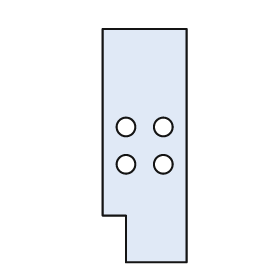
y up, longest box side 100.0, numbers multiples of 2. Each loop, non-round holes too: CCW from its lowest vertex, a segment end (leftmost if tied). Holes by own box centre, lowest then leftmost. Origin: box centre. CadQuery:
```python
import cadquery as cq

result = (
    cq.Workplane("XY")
    .moveTo(-8.0, -50.0)
    .lineTo(18.0, -50.0)
    .lineTo(18.0, 50.0)
    .lineTo(-18.0, 50.0)
    .lineTo(-18.0, -30.0)
    .lineTo(-8.0, -30.0)
    .close()
    .moveTo(-8.0, -8.0)
    .circle(4.0)
    .moveTo(8.0, -8.0)
    .circle(4.0)
    .moveTo(-8.0, 8.0)
    .circle(4.0)
    .moveTo(8.0, 8.0)
    .circle(4.0)
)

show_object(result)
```